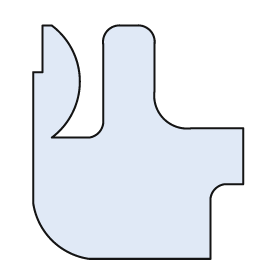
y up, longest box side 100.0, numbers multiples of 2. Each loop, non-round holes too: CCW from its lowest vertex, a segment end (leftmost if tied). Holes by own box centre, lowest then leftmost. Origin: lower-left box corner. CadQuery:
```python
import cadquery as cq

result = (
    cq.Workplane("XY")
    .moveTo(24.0, 0.0)
    .lineTo(76.0, 0.0)
    .lineTo(76.0, 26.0)
    .threePointArc((78.0, 30.0), (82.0, 32.0))
    .lineTo(90.0, 32.0)
    .lineTo(90.0, 56.0)
    .lineTo(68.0, 56.0)
    .threePointArc((56.0, 60.0), (52.0, 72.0))
    .lineTo(52.0, 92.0)
    .threePointArc((50.0, 98.0), (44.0, 100.0))
    .lineTo(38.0, 100.0)
    .threePointArc((32.0, 98.0), (30.0, 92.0))
    .lineTo(30.0, 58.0)
    .threePointArc((28.0, 54.0), (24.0, 52.0))
    .lineTo(8.0, 52.0)
    .threePointArc((20.0, 76.0), (8.0, 100.0))
    .lineTo(4.0, 100.0)
    .lineTo(4.0, 80.0)
    .lineTo(0.0, 80.0)
    .lineTo(0.0, 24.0)
    .threePointArc((8.0, 8.0), (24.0, 0.0))
    .close()
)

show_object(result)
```